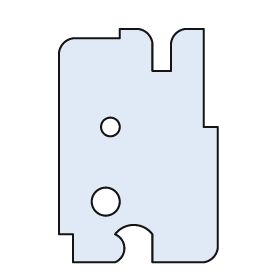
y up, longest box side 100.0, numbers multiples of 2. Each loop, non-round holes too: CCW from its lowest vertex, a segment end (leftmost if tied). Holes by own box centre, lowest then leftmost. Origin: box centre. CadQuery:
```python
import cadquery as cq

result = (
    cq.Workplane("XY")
    .moveTo(-28.0, -50.0)
    .lineTo(-10.0, -50.0)
    .threePointArc((-6.0, -44.0), (-10.0, -38.0))
    .threePointArc((-2.0, -34.0), (6.0, -38.0))
    .lineTo(6.0, -50.0)
    .lineTo(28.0, -50.0)
    .threePointArc((32.0, -48.0), (34.0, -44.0))
    .lineTo(34.0, 8.0)
    .lineTo(28.0, 8.0)
    .lineTo(28.0, 50.0)
    .lineTo(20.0, 50.0)
    .threePointArc((16.0, 48.0), (14.0, 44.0))
    .lineTo(14.0, 32.0)
    .lineTo(6.0, 32.0)
    .lineTo(6.0, 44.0)
    .threePointArc((4.0, 48.0), (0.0, 50.0))
    .lineTo(-8.0, 50.0)
    .lineTo(-8.0, 46.0)
    .lineTo(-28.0, 46.0)
    .threePointArc((-32.0, 44.0), (-34.0, 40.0))
    .lineTo(-34.0, -38.0)
    .lineTo(-28.0, -38.0)
    .close()
    .moveTo(-14.0, -24.0)
    .circle(6.0)
    .moveTo(-12.0, 8.0)
    .circle(4.0)
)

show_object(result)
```